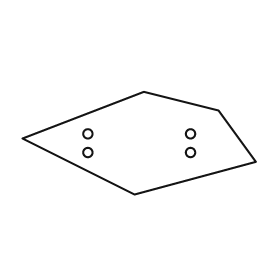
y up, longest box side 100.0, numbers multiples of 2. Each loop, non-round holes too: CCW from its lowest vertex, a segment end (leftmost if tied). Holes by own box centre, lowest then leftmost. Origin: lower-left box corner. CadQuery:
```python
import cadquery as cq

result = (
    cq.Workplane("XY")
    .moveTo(48.0, 0.0)
    .lineTo(100.0, 14.0)
    .lineTo(84.0, 36.0)
    .lineTo(52.0, 44.0)
    .lineTo(0.0, 24.0)
    .close()
    .moveTo(28.0, 18.0)
    .circle(2.0)
    .moveTo(72.0, 18.0)
    .circle(2.0)
    .moveTo(28.0, 26.0)
    .circle(2.0)
    .moveTo(72.0, 26.0)
    .circle(2.0)
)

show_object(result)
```